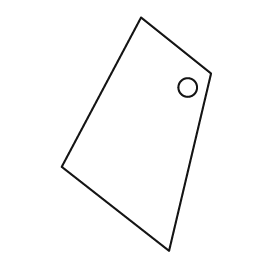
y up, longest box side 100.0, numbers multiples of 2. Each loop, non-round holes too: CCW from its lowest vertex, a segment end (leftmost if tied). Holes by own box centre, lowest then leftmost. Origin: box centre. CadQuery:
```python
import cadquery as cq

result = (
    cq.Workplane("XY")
    .moveTo(14.0, -50.0)
    .lineTo(32.0, 26.0)
    .lineTo(2.0, 50.0)
    .lineTo(-32.0, -14.0)
    .close()
    .moveTo(22.0, 20.0)
    .circle(4.0)
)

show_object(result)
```